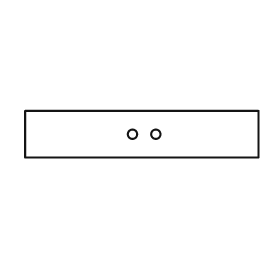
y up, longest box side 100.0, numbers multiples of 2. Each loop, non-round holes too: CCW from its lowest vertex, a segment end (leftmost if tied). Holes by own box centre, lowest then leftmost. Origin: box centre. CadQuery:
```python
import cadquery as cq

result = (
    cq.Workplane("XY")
    .moveTo(-50.0, -10.0)
    .lineTo(50.0, -10.0)
    .lineTo(50.0, 10.0)
    .lineTo(-50.0, 10.0)
    .close()
    .moveTo(-4.0, 0.0)
    .circle(2.0)
    .moveTo(6.0, 0.0)
    .circle(2.0)
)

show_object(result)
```